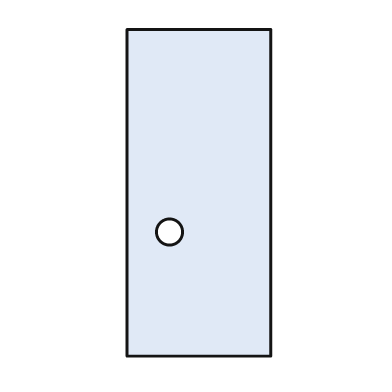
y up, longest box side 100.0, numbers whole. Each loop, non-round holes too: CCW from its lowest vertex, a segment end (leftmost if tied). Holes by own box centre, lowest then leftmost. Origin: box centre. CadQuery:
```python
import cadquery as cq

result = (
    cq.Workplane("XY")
    .moveTo(-22.0, -50.0)
    .lineTo(22.0, -50.0)
    .lineTo(22.0, 50.0)
    .lineTo(-22.0, 50.0)
    .close()
    .moveTo(-9.0, -12.0)
    .circle(4.0)
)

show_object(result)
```